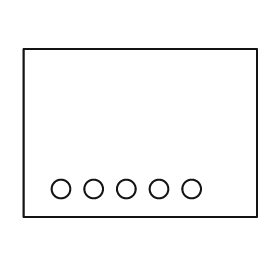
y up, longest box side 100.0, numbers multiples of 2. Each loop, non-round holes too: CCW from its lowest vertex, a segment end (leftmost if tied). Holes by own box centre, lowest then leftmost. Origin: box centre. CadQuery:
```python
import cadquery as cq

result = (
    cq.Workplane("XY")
    .moveTo(-50.0, -36.0)
    .lineTo(50.0, -36.0)
    .lineTo(50.0, 36.0)
    .lineTo(-50.0, 36.0)
    .close()
    .moveTo(-34.0, -24.0)
    .circle(4.0)
    .moveTo(-20.0, -24.0)
    .circle(4.0)
    .moveTo(-6.0, -24.0)
    .circle(4.0)
    .moveTo(8.0, -24.0)
    .circle(4.0)
    .moveTo(22.0, -24.0)
    .circle(4.0)
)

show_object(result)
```